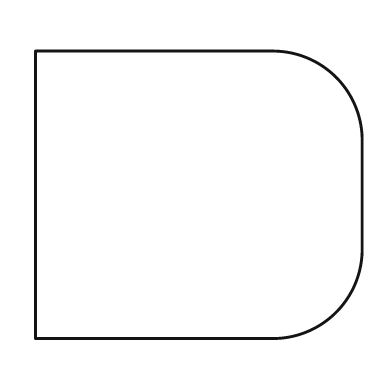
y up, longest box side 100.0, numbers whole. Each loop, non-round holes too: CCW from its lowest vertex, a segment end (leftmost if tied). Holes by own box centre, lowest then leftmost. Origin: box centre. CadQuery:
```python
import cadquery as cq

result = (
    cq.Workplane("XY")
    .moveTo(-50.0, -44.0)
    .lineTo(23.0, -44.0)
    .threePointArc((42.0, -36.0), (50.0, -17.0))
    .lineTo(50.0, 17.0)
    .threePointArc((42.0, 36.0), (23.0, 44.0))
    .lineTo(-50.0, 44.0)
    .close()
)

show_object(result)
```